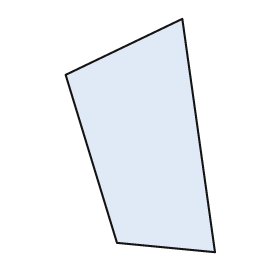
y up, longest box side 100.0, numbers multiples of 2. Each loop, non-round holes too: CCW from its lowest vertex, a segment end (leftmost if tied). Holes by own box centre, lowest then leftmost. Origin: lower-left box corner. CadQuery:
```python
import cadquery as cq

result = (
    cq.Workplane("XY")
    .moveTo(64.0, 0.0)
    .lineTo(50.0, 100.0)
    .lineTo(0.0, 76.0)
    .lineTo(22.0, 4.0)
    .close()
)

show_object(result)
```